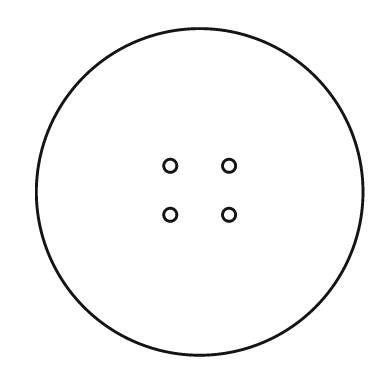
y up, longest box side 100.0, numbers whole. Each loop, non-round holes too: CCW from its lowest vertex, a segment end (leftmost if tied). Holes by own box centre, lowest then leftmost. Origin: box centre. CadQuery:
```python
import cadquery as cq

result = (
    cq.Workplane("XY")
    .moveTo(0.0, 0.0)
    .circle(50.0)
    .moveTo(-9.0, -7.0)
    .circle(2.0)
    .moveTo(9.0, -7.0)
    .circle(2.0)
    .moveTo(-9.0, 8.0)
    .circle(2.0)
    .moveTo(9.0, 8.0)
    .circle(2.0)
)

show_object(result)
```